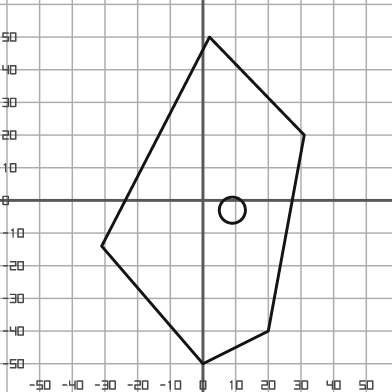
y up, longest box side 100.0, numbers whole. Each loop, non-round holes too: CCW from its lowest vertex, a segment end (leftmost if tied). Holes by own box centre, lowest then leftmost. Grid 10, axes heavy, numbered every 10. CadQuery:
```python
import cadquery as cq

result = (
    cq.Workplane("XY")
    .moveTo(0.0, -50.0)
    .lineTo(20.0, -40.0)
    .lineTo(31.0, 20.0)
    .lineTo(2.0, 50.0)
    .lineTo(-31.0, -14.0)
    .close()
    .moveTo(9.0, -3.0)
    .circle(4.0)
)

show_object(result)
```